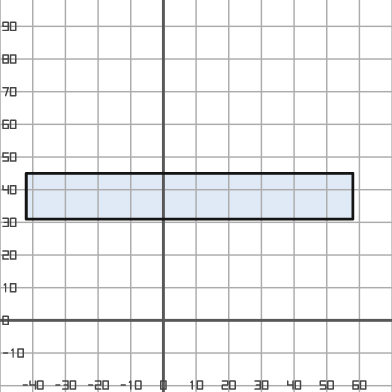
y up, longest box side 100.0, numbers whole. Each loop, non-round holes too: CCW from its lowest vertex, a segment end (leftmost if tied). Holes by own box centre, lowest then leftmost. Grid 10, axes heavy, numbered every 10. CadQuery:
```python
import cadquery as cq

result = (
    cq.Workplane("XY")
    .moveTo(-42.0, 31.0)
    .lineTo(58.0, 31.0)
    .lineTo(58.0, 45.0)
    .lineTo(-42.0, 45.0)
    .close()
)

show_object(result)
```